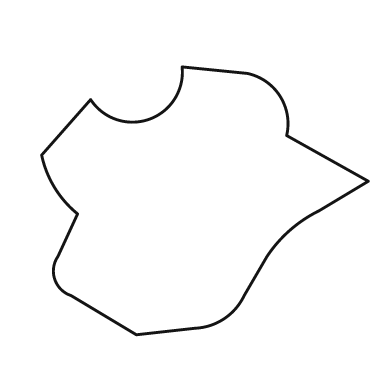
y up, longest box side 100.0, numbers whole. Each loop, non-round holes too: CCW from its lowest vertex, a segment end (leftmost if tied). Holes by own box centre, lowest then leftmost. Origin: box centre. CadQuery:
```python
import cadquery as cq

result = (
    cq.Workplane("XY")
    .moveTo(-21.0, -41.0)
    .lineTo(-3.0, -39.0)
    .threePointArc((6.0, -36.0), (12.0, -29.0))
    .lineTo(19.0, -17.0)
    .threePointArc((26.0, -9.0), (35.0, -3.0))
    .lineTo(50.0, 6.0)
    .lineTo(25.0, 20.0)
    .threePointArc((23.0, 32.0), (13.0, 39.0))
    .lineTo(-7.0, 41.0)
    .threePointArc((-17.0, 25.0), (-35.0, 31.0))
    .lineTo(-50.0, 14.0)
    .threePointArc((-46.0, 4.0), (-39.0, -4.0))
    .lineTo(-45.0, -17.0)
    .threePointArc((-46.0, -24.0), (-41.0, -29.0))
    .close()
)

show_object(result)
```